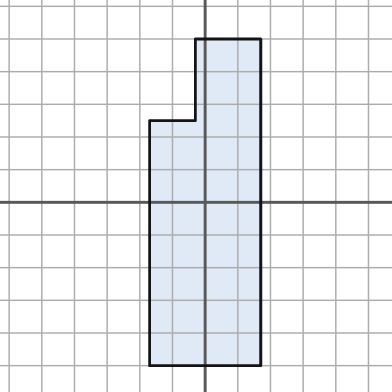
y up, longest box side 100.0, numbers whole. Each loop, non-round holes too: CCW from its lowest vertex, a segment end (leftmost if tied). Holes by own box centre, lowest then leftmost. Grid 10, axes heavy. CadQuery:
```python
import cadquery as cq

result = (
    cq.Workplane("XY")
    .moveTo(-17.0, -50.0)
    .lineTo(17.0, -50.0)
    .lineTo(17.0, 50.0)
    .lineTo(-3.0, 50.0)
    .lineTo(-3.0, 25.0)
    .lineTo(-17.0, 25.0)
    .close()
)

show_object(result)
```